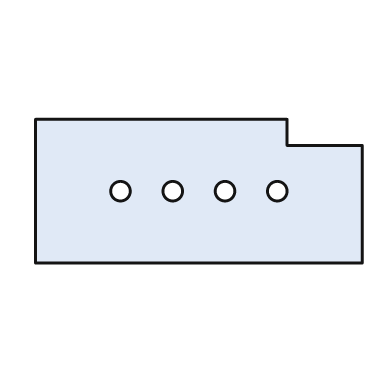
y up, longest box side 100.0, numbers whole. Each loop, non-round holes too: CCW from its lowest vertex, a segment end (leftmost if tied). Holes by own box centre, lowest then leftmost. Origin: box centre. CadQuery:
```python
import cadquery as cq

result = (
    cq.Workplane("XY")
    .moveTo(-50.0, -22.0)
    .lineTo(50.0, -22.0)
    .lineTo(50.0, 14.0)
    .lineTo(27.0, 14.0)
    .lineTo(27.0, 22.0)
    .lineTo(-50.0, 22.0)
    .close()
    .moveTo(-24.0, 0.0)
    .circle(3.0)
    .moveTo(-8.0, 0.0)
    .circle(3.0)
    .moveTo(8.0, 0.0)
    .circle(3.0)
    .moveTo(24.0, 0.0)
    .circle(3.0)
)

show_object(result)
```